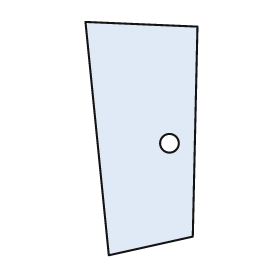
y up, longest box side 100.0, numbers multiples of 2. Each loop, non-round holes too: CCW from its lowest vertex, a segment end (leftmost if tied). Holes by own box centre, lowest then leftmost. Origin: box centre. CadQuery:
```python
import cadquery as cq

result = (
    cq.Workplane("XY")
    .moveTo(-14.0, -50.0)
    .lineTo(22.0, -42.0)
    .lineTo(24.0, 48.0)
    .lineTo(-24.0, 50.0)
    .close()
    .moveTo(12.0, -2.0)
    .circle(4.0)
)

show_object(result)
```